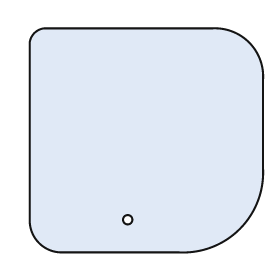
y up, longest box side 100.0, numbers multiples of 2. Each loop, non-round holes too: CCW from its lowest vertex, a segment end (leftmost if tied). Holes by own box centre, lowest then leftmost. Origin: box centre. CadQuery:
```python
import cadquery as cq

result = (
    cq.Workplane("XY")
    .moveTo(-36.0, -48.0)
    .lineTo(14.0, -48.0)
    .threePointArc((40.0, -38.0), (50.0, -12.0))
    .lineTo(50.0, 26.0)
    .threePointArc((44.0, 42.0), (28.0, 48.0))
    .lineTo(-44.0, 48.0)
    .threePointArc((-48.0, 46.0), (-50.0, 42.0))
    .lineTo(-50.0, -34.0)
    .threePointArc((-46.0, -44.0), (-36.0, -48.0))
    .close()
    .moveTo(-8.0, -34.0)
    .circle(2.0)
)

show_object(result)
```